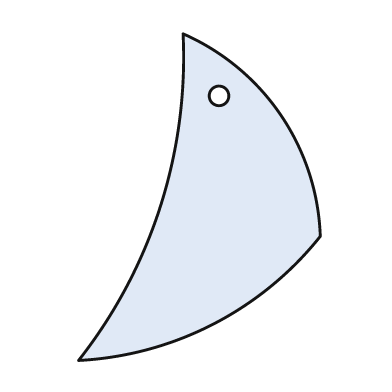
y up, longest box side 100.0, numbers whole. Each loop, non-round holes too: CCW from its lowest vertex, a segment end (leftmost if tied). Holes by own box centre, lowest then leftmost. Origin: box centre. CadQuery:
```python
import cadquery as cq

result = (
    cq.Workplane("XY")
    .moveTo(-37.0, -50.0)
    .threePointArc((4.0, -39.0), (37.0, -12.0))
    .threePointArc((25.0, 25.0), (-5.0, 50.0))
    .threePointArc((-12.0, -3.0), (-37.0, -50.0))
    .close()
    .moveTo(6.0, 31.0)
    .circle(3.0)
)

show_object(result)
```